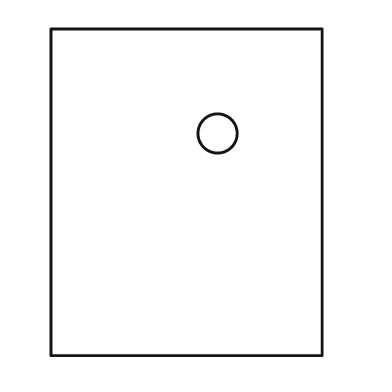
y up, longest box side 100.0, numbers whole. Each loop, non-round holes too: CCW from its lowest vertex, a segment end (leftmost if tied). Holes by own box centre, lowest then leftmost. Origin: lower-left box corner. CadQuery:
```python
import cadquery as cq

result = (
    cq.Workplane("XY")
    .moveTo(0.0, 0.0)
    .lineTo(83.0, 0.0)
    .lineTo(83.0, 100.0)
    .lineTo(0.0, 100.0)
    .close()
    .moveTo(51.0, 68.0)
    .circle(6.0)
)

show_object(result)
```